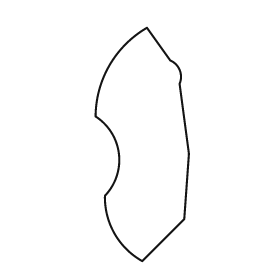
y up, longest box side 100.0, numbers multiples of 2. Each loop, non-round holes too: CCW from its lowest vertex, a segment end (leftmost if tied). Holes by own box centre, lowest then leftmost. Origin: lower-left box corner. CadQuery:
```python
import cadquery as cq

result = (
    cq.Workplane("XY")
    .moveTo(20.0, 0.0)
    .lineTo(38.0, 18.0)
    .lineTo(40.0, 46.0)
    .lineTo(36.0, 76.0)
    .threePointArc((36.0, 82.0), (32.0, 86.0))
    .lineTo(22.0, 100.0)
    .threePointArc((6.0, 84.0), (0.0, 62.0))
    .threePointArc((10.0, 46.0), (4.0, 28.0))
    .threePointArc((8.0, 12.0), (20.0, 0.0))
    .close()
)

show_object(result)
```